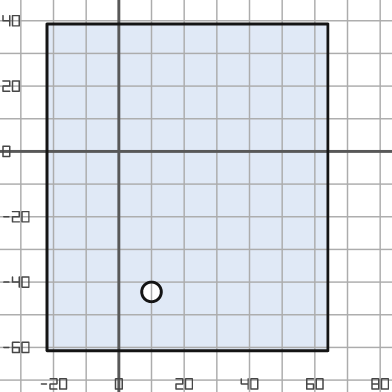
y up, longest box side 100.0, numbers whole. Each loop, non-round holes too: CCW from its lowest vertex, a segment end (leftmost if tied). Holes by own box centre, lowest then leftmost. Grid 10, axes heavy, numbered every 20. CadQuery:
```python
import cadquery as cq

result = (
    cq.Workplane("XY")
    .moveTo(-22.0, -61.0)
    .lineTo(64.0, -61.0)
    .lineTo(64.0, 39.0)
    .lineTo(-22.0, 39.0)
    .close()
    .moveTo(10.0, -43.0)
    .circle(3.0)
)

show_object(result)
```